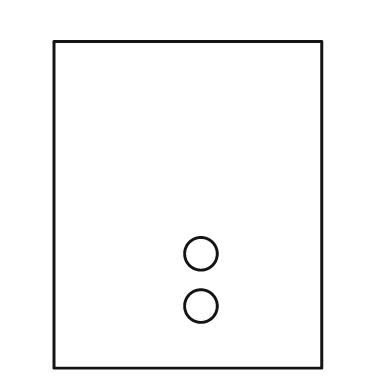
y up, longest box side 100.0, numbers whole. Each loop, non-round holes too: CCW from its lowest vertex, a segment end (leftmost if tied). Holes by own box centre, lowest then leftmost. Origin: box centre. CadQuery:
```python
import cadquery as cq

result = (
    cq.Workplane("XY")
    .moveTo(-41.0, -50.0)
    .lineTo(41.0, -50.0)
    .lineTo(41.0, 50.0)
    .lineTo(-41.0, 50.0)
    .close()
    .moveTo(4.0, -31.0)
    .circle(5.0)
    .moveTo(4.0, -15.0)
    .circle(5.0)
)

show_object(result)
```